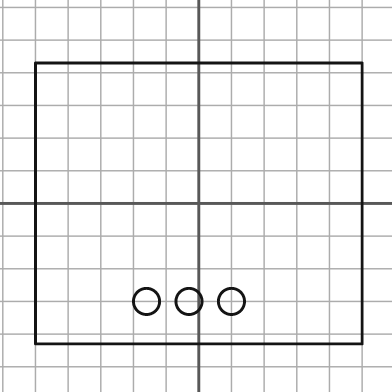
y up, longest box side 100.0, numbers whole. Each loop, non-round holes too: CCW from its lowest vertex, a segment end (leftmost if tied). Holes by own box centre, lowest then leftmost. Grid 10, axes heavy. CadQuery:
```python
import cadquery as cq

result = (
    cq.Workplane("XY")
    .moveTo(-50.0, -43.0)
    .lineTo(50.0, -43.0)
    .lineTo(50.0, 43.0)
    .lineTo(-50.0, 43.0)
    .close()
    .moveTo(-16.0, -30.0)
    .circle(4.0)
    .moveTo(-3.0, -30.0)
    .circle(4.0)
    .moveTo(10.0, -30.0)
    .circle(4.0)
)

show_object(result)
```